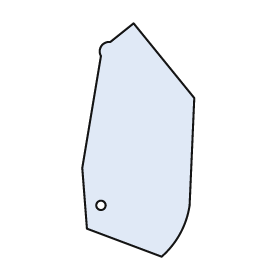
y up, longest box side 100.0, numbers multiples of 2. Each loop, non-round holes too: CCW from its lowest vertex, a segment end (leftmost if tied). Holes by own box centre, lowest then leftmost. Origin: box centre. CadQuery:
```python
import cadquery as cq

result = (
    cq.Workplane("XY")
    .moveTo(10.0, -50.0)
    .threePointArc((18.0, -40.0), (22.0, -28.0))
    .lineTo(24.0, 18.0)
    .lineTo(-2.0, 50.0)
    .lineTo(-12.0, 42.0)
    .threePointArc((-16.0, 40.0), (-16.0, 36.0))
    .lineTo(-24.0, -12.0)
    .lineTo(-22.0, -38.0)
    .close()
    .moveTo(-16.0, -28.0)
    .circle(2.0)
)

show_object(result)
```